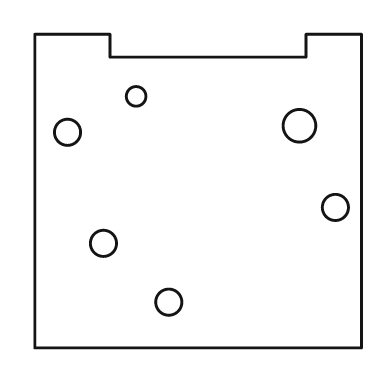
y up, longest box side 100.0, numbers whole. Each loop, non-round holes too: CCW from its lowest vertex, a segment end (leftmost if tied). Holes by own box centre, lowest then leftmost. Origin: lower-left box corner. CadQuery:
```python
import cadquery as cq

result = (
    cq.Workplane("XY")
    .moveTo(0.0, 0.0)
    .lineTo(100.0, 0.0)
    .lineTo(100.0, 96.0)
    .lineTo(83.0, 96.0)
    .lineTo(83.0, 89.0)
    .lineTo(23.0, 89.0)
    .lineTo(23.0, 96.0)
    .lineTo(0.0, 96.0)
    .close()
    .moveTo(41.0, 14.0)
    .circle(4.0)
    .moveTo(21.0, 32.0)
    .circle(4.0)
    .moveTo(92.0, 43.0)
    .circle(4.0)
    .moveTo(10.0, 66.0)
    .circle(4.0)
    .moveTo(81.0, 68.0)
    .circle(5.0)
    .moveTo(31.0, 77.0)
    .circle(3.0)
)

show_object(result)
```